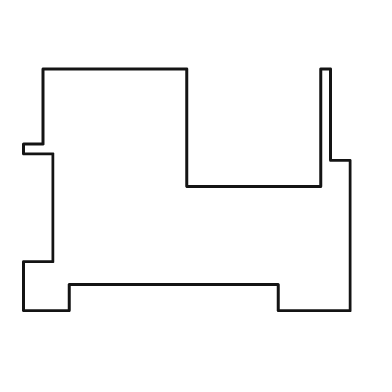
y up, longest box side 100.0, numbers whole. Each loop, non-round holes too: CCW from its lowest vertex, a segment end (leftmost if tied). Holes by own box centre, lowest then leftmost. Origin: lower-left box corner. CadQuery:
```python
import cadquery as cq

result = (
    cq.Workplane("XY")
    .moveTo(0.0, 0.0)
    .lineTo(14.0, 0.0)
    .lineTo(14.0, 8.0)
    .lineTo(78.0, 8.0)
    .lineTo(78.0, 0.0)
    .lineTo(100.0, 0.0)
    .lineTo(100.0, 46.0)
    .lineTo(94.0, 46.0)
    .lineTo(94.0, 74.0)
    .lineTo(91.0, 74.0)
    .lineTo(91.0, 38.0)
    .lineTo(50.0, 38.0)
    .lineTo(50.0, 74.0)
    .lineTo(6.0, 74.0)
    .lineTo(6.0, 51.0)
    .lineTo(0.0, 51.0)
    .lineTo(0.0, 48.0)
    .lineTo(9.0, 48.0)
    .lineTo(9.0, 15.0)
    .lineTo(0.0, 15.0)
    .close()
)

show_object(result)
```